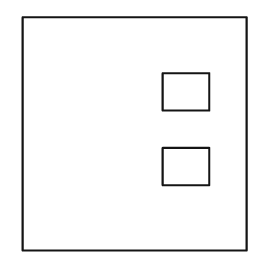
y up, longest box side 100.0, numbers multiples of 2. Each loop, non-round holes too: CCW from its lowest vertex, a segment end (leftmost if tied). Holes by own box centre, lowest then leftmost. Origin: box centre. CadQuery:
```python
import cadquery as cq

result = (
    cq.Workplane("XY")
    .moveTo(-48.0, -50.0)
    .lineTo(48.0, -50.0)
    .lineTo(48.0, 50.0)
    .lineTo(-48.0, 50.0)
    .close()
    .moveTo(12.0, -22.0)
    .lineTo(32.0, -22.0)
    .lineTo(32.0, -6.0)
    .lineTo(12.0, -6.0)
    .close()
    .moveTo(12.0, 10.0)
    .lineTo(32.0, 10.0)
    .lineTo(32.0, 26.0)
    .lineTo(12.0, 26.0)
    .close()
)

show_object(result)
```